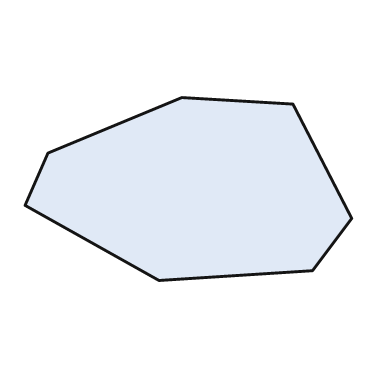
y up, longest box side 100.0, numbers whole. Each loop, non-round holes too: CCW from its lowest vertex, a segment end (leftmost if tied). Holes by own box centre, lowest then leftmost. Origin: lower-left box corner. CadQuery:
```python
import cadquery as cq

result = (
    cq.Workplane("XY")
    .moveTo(41.0, 0.0)
    .lineTo(88.0, 3.0)
    .lineTo(100.0, 19.0)
    .lineTo(82.0, 54.0)
    .lineTo(48.0, 56.0)
    .lineTo(7.0, 39.0)
    .lineTo(0.0, 23.0)
    .close()
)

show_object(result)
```